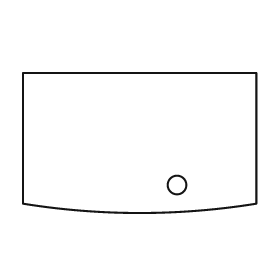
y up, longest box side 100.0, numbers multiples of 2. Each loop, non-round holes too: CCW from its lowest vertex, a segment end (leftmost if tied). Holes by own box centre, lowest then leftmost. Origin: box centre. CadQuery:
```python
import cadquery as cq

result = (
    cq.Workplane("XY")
    .moveTo(-50.0, -26.0)
    .threePointArc((0.0, -30.0), (50.0, -26.0))
    .lineTo(50.0, 30.0)
    .lineTo(-50.0, 30.0)
    .close()
    .moveTo(16.0, -18.0)
    .circle(4.0)
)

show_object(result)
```